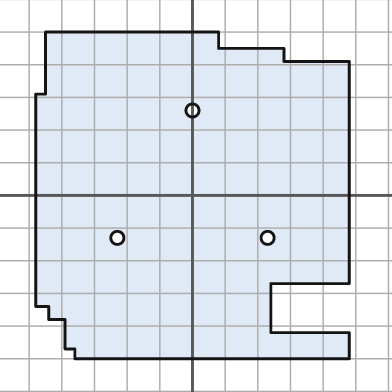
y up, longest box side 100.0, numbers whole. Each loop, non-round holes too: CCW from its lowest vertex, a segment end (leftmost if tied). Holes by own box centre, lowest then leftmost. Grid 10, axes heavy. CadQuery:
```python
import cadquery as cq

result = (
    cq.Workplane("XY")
    .moveTo(-36.0, -50.0)
    .lineTo(48.0, -50.0)
    .lineTo(48.0, -42.0)
    .lineTo(24.0, -42.0)
    .lineTo(24.0, -27.0)
    .lineTo(48.0, -27.0)
    .lineTo(48.0, 41.0)
    .lineTo(28.0, 41.0)
    .lineTo(28.0, 45.0)
    .lineTo(8.0, 45.0)
    .lineTo(8.0, 50.0)
    .lineTo(-45.0, 50.0)
    .lineTo(-45.0, 31.0)
    .lineTo(-48.0, 31.0)
    .lineTo(-48.0, -34.0)
    .lineTo(-44.0, -34.0)
    .lineTo(-44.0, -38.0)
    .lineTo(-39.0, -38.0)
    .lineTo(-39.0, -47.0)
    .lineTo(-36.0, -47.0)
    .close()
    .moveTo(-23.0, -13.0)
    .circle(2.0)
    .moveTo(23.0, -13.0)
    .circle(2.0)
    .moveTo(0.0, 26.0)
    .circle(2.0)
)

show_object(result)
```